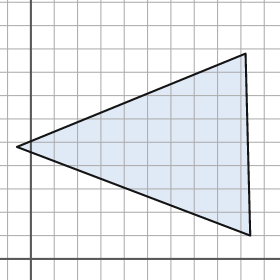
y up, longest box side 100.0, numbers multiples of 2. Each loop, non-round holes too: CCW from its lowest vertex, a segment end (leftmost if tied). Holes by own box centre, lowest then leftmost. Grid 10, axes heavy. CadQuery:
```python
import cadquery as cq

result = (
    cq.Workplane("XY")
    .moveTo(94.0, 10.0)
    .lineTo(92.0, 88.0)
    .lineTo(-6.0, 48.0)
    .close()
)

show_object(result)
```